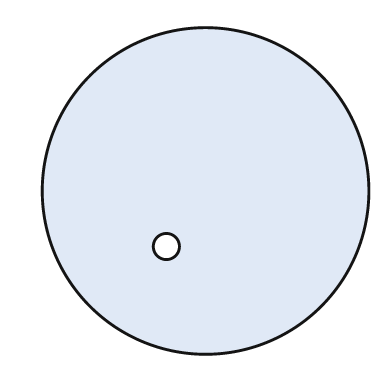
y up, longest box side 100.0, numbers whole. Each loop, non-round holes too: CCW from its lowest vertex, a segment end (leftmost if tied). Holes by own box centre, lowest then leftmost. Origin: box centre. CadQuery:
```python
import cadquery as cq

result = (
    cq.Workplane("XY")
    .moveTo(0.0, 0.0)
    .circle(50.0)
    .moveTo(-12.0, -17.0)
    .circle(4.0)
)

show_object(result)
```